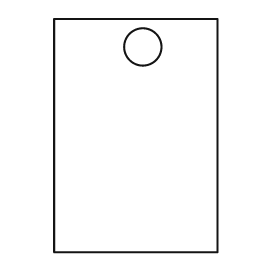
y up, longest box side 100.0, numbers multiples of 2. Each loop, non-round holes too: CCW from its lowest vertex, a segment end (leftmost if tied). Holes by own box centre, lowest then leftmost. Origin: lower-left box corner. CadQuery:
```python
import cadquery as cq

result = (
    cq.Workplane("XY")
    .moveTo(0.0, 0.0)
    .lineTo(70.0, 0.0)
    .lineTo(70.0, 100.0)
    .lineTo(0.0, 100.0)
    .close()
    .moveTo(38.0, 88.0)
    .circle(8.0)
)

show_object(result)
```